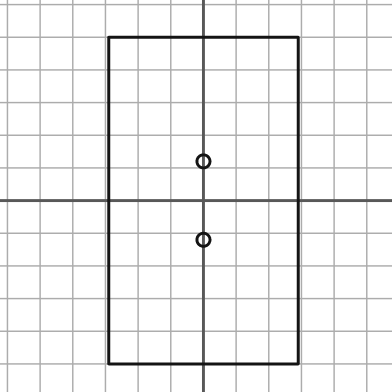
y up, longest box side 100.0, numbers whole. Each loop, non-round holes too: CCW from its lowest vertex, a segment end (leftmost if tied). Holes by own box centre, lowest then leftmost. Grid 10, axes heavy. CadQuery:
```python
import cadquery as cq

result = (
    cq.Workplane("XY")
    .moveTo(-29.0, -50.0)
    .lineTo(29.0, -50.0)
    .lineTo(29.0, 50.0)
    .lineTo(-29.0, 50.0)
    .close()
    .moveTo(0.0, -12.0)
    .circle(2.0)
    .moveTo(0.0, 12.0)
    .circle(2.0)
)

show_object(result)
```